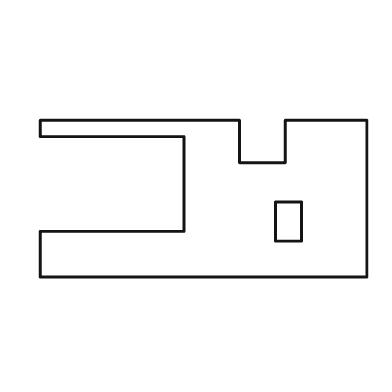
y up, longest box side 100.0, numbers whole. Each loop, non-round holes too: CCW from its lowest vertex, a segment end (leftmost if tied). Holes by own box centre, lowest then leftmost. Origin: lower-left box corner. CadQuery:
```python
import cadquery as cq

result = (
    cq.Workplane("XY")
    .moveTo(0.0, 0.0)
    .lineTo(100.0, 0.0)
    .lineTo(100.0, 48.0)
    .lineTo(75.0, 48.0)
    .lineTo(75.0, 35.0)
    .lineTo(61.0, 35.0)
    .lineTo(61.0, 48.0)
    .lineTo(0.0, 48.0)
    .lineTo(0.0, 43.0)
    .lineTo(44.0, 43.0)
    .lineTo(44.0, 14.0)
    .lineTo(0.0, 14.0)
    .close()
    .moveTo(72.0, 11.0)
    .lineTo(80.0, 11.0)
    .lineTo(80.0, 23.0)
    .lineTo(72.0, 23.0)
    .close()
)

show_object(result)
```